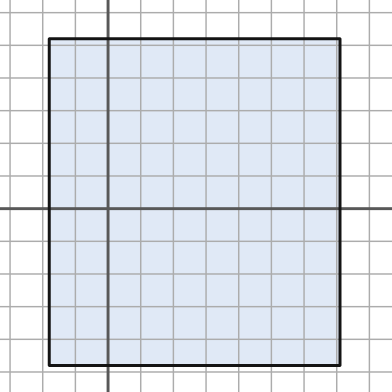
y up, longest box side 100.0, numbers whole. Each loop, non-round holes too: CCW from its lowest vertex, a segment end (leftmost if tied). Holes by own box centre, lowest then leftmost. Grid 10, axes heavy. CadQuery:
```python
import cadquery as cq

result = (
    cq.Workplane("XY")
    .moveTo(-18.0, -48.0)
    .lineTo(71.0, -48.0)
    .lineTo(71.0, 52.0)
    .lineTo(-18.0, 52.0)
    .close()
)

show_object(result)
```